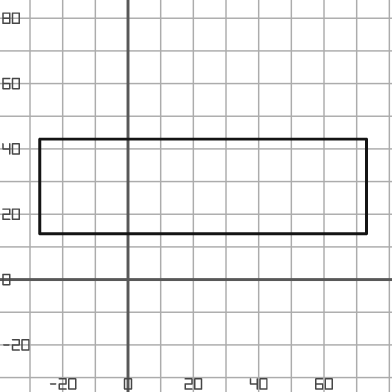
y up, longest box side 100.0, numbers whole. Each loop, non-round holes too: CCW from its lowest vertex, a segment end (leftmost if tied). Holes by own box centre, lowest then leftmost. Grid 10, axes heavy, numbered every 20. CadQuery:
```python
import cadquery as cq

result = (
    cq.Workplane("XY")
    .moveTo(-27.0, 14.0)
    .lineTo(73.0, 14.0)
    .lineTo(73.0, 43.0)
    .lineTo(-27.0, 43.0)
    .close()
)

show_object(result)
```